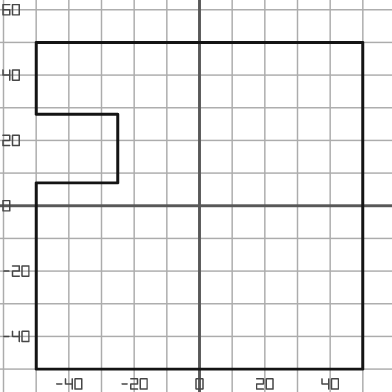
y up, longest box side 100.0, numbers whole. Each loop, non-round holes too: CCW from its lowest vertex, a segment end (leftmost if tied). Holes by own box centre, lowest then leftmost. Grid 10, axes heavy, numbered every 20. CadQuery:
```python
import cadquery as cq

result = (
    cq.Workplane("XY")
    .moveTo(-50.0, -50.0)
    .lineTo(50.0, -50.0)
    .lineTo(50.0, 50.0)
    .lineTo(-50.0, 50.0)
    .lineTo(-50.0, 28.0)
    .lineTo(-25.0, 28.0)
    .lineTo(-25.0, 7.0)
    .lineTo(-50.0, 7.0)
    .close()
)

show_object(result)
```